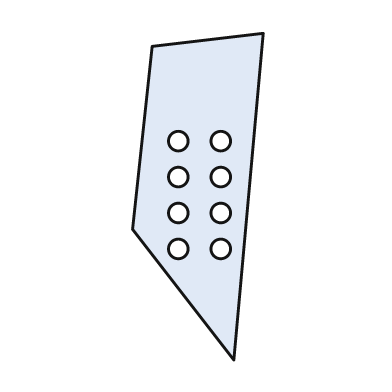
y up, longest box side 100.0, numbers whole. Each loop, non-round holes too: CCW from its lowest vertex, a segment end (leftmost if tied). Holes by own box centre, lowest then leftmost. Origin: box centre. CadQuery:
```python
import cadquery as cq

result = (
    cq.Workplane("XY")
    .moveTo(11.0, -50.0)
    .lineTo(20.0, 50.0)
    .lineTo(-14.0, 46.0)
    .lineTo(-20.0, -10.0)
    .close()
    .moveTo(-6.0, -16.0)
    .circle(3.0)
    .moveTo(7.0, -16.0)
    .circle(3.0)
    .moveTo(-6.0, -5.0)
    .circle(3.0)
    .moveTo(7.0, -5.0)
    .circle(3.0)
    .moveTo(-6.0, 6.0)
    .circle(3.0)
    .moveTo(7.0, 6.0)
    .circle(3.0)
    .moveTo(-6.0, 17.0)
    .circle(3.0)
    .moveTo(7.0, 17.0)
    .circle(3.0)
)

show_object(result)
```